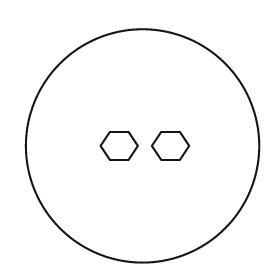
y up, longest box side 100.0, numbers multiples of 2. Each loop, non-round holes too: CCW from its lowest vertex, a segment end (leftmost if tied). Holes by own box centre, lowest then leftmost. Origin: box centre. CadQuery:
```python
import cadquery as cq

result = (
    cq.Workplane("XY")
    .moveTo(0.0, 0.0)
    .circle(50.0)
    .moveTo(-14.0, -6.0)
    .lineTo(-6.0, -6.0)
    .lineTo(-2.0, 0.0)
    .lineTo(-6.0, 6.0)
    .lineTo(-14.0, 6.0)
    .lineTo(-18.0, 0.0)
    .close()
    .moveTo(8.0, -6.0)
    .lineTo(16.0, -6.0)
    .lineTo(20.0, 0.0)
    .lineTo(16.0, 6.0)
    .lineTo(8.0, 6.0)
    .lineTo(4.0, 0.0)
    .close()
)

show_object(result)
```